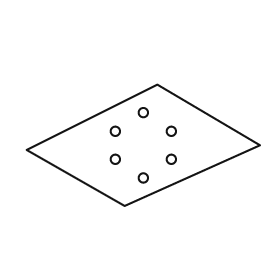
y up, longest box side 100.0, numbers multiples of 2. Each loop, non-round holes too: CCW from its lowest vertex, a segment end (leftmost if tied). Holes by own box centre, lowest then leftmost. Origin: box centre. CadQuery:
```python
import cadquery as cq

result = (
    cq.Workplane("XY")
    .moveTo(-8.0, -26.0)
    .lineTo(50.0, 0.0)
    .lineTo(6.0, 26.0)
    .lineTo(-50.0, -2.0)
    .close()
    .moveTo(0.0, -14.0)
    .circle(2.0)
    .moveTo(-12.0, -6.0)
    .circle(2.0)
    .moveTo(12.0, -6.0)
    .circle(2.0)
    .moveTo(-12.0, 6.0)
    .circle(2.0)
    .moveTo(12.0, 6.0)
    .circle(2.0)
    .moveTo(0.0, 14.0)
    .circle(2.0)
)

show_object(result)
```